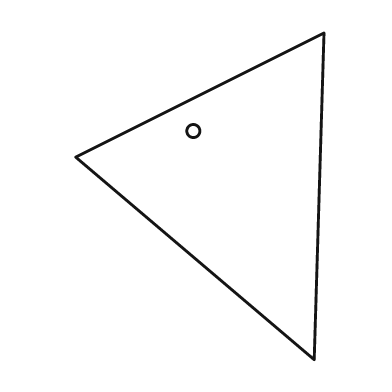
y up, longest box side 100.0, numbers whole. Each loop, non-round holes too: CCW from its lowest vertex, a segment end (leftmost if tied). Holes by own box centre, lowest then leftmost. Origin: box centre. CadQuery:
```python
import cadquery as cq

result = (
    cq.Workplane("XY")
    .moveTo(35.0, -50.0)
    .lineTo(38.0, 50.0)
    .lineTo(-38.0, 12.0)
    .close()
    .moveTo(-2.0, 20.0)
    .circle(2.0)
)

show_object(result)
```